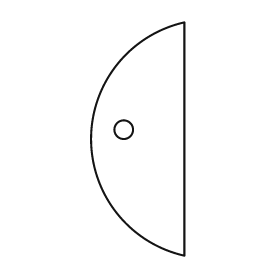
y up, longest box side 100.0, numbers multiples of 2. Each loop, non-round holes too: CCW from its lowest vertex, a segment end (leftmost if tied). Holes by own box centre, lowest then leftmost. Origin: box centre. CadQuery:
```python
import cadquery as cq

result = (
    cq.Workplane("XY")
    .moveTo(20.0, -50.0)
    .lineTo(20.0, 50.0)
    .threePointArc((-20.0, 0.0), (20.0, -50.0))
    .close()
    .moveTo(-6.0, 4.0)
    .circle(4.0)
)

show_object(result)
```